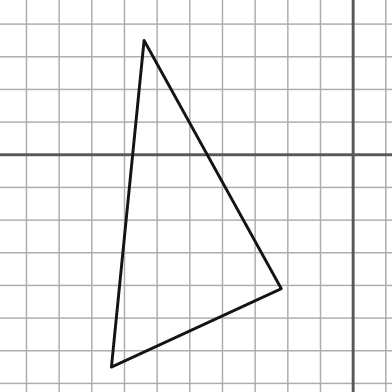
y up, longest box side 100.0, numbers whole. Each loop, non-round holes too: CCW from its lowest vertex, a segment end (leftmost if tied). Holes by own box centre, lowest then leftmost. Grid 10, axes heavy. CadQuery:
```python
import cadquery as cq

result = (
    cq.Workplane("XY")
    .moveTo(-74.0, -65.0)
    .lineTo(-22.0, -41.0)
    .lineTo(-64.0, 35.0)
    .close()
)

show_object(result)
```